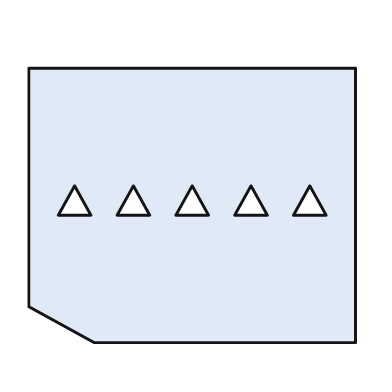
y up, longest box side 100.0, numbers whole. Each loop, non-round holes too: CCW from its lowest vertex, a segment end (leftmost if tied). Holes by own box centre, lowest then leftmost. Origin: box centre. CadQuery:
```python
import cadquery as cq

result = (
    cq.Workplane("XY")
    .moveTo(-30.0, -42.0)
    .lineTo(50.0, -42.0)
    .lineTo(50.0, 42.0)
    .lineTo(-50.0, 42.0)
    .lineTo(-50.0, -31.0)
    .close()
    .moveTo(-41.0, -3.0)
    .lineTo(-31.0, -3.0)
    .lineTo(-36.0, 6.0)
    .close()
    .moveTo(-23.0, -3.0)
    .lineTo(-13.0, -3.0)
    .lineTo(-18.0, 6.0)
    .close()
    .moveTo(-5.0, -3.0)
    .lineTo(5.0, -3.0)
    .lineTo(0.0, 6.0)
    .close()
    .moveTo(13.0, -3.0)
    .lineTo(23.0, -3.0)
    .lineTo(18.0, 6.0)
    .close()
    .moveTo(31.0, -3.0)
    .lineTo(41.0, -3.0)
    .lineTo(36.0, 6.0)
    .close()
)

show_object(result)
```